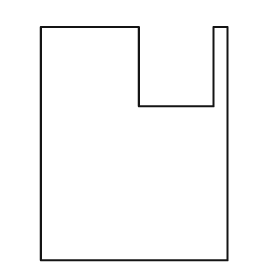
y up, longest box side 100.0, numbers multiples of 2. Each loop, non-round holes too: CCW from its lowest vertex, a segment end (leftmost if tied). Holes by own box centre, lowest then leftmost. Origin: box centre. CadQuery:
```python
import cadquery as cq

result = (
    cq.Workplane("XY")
    .moveTo(-40.0, -50.0)
    .lineTo(40.0, -50.0)
    .lineTo(40.0, 50.0)
    .lineTo(34.0, 50.0)
    .lineTo(34.0, 16.0)
    .lineTo(2.0, 16.0)
    .lineTo(2.0, 50.0)
    .lineTo(-40.0, 50.0)
    .close()
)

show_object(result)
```